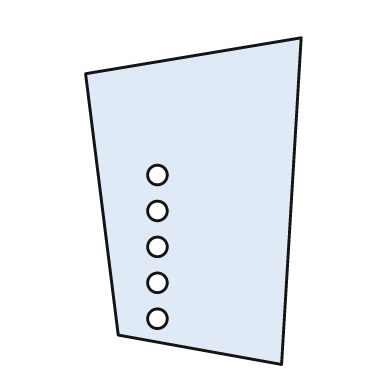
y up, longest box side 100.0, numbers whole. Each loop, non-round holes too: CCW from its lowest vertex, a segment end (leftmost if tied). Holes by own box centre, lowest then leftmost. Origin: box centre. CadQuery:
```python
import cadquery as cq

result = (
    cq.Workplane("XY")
    .moveTo(27.0, -50.0)
    .lineTo(33.0, 50.0)
    .lineTo(-33.0, 39.0)
    .lineTo(-23.0, -41.0)
    .close()
    .moveTo(-11.0, -36.0)
    .circle(3.0)
    .moveTo(-11.0, -25.0)
    .circle(3.0)
    .moveTo(-11.0, -14.0)
    .circle(3.0)
    .moveTo(-11.0, -3.0)
    .circle(3.0)
    .moveTo(-11.0, 8.0)
    .circle(3.0)
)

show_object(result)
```